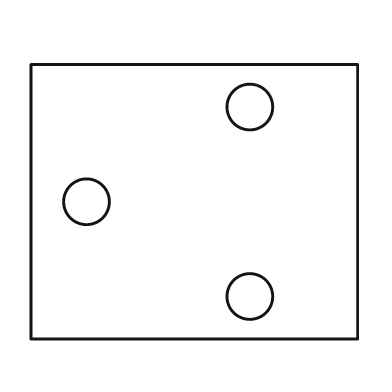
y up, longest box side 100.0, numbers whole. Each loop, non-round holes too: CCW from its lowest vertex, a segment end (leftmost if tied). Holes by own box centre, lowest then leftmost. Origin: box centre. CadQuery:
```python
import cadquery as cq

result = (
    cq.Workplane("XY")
    .moveTo(-50.0, -42.0)
    .lineTo(50.0, -42.0)
    .lineTo(50.0, 42.0)
    .lineTo(-50.0, 42.0)
    .close()
    .moveTo(17.0, -29.0)
    .circle(7.0)
    .moveTo(-33.0, 0.0)
    .circle(7.0)
    .moveTo(17.0, 29.0)
    .circle(7.0)
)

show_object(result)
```